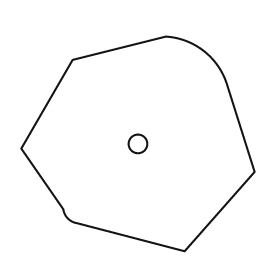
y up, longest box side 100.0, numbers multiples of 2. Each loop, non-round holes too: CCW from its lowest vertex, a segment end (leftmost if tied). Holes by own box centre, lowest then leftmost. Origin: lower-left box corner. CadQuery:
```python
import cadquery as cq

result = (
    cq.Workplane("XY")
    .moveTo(70.0, 0.0)
    .lineTo(100.0, 34.0)
    .lineTo(88.0, 72.0)
    .threePointArc((78.0, 86.0), (62.0, 92.0))
    .lineTo(22.0, 82.0)
    .lineTo(0.0, 44.0)
    .lineTo(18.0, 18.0)
    .threePointArc((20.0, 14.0), (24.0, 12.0))
    .close()
    .moveTo(50.0, 46.0)
    .circle(4.0)
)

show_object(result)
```